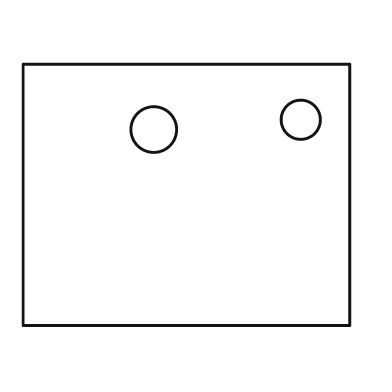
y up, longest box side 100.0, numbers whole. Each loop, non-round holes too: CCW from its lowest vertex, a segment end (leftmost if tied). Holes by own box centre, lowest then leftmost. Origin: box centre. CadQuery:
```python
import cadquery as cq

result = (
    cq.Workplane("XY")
    .moveTo(-50.0, -40.0)
    .lineTo(50.0, -40.0)
    .lineTo(50.0, 40.0)
    .lineTo(-50.0, 40.0)
    .close()
    .moveTo(-10.0, 20.0)
    .circle(7.0)
    .moveTo(35.0, 23.0)
    .circle(6.0)
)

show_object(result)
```